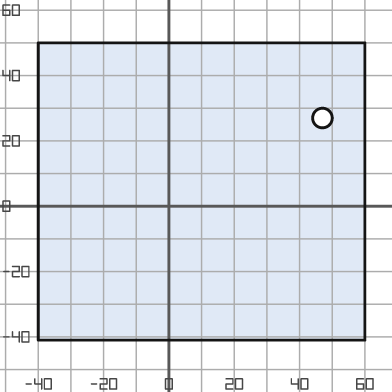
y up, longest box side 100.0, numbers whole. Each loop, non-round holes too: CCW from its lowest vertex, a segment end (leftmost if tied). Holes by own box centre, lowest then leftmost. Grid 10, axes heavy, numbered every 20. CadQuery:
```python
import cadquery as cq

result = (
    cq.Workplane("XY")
    .moveTo(-40.0, -41.0)
    .lineTo(60.0, -41.0)
    .lineTo(60.0, 50.0)
    .lineTo(-40.0, 50.0)
    .close()
    .moveTo(47.0, 27.0)
    .circle(3.0)
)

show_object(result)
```